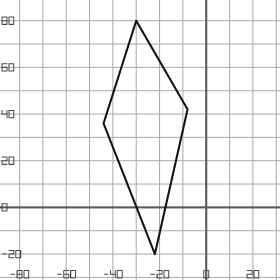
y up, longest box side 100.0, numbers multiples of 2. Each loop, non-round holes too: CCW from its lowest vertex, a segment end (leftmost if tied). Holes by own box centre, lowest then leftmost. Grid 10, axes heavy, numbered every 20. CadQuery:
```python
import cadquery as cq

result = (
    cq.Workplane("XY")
    .moveTo(-22.0, -20.0)
    .lineTo(-8.0, 42.0)
    .lineTo(-30.0, 80.0)
    .lineTo(-44.0, 36.0)
    .close()
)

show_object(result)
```